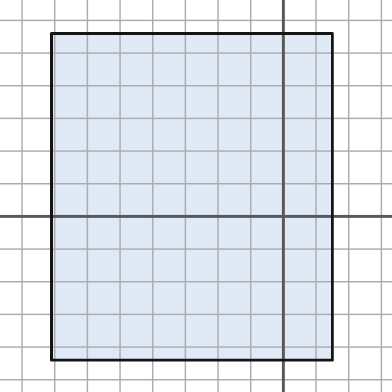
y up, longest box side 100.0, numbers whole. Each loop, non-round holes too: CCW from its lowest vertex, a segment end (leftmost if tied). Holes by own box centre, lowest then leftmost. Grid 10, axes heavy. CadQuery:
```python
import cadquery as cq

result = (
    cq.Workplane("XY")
    .moveTo(-71.0, -44.0)
    .lineTo(15.0, -44.0)
    .lineTo(15.0, 56.0)
    .lineTo(-71.0, 56.0)
    .close()
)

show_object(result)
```